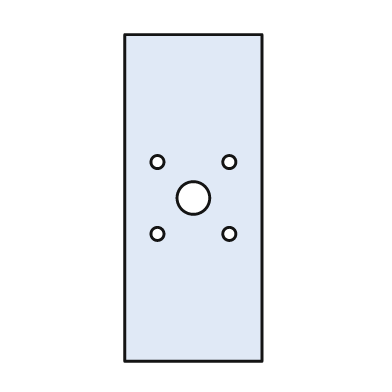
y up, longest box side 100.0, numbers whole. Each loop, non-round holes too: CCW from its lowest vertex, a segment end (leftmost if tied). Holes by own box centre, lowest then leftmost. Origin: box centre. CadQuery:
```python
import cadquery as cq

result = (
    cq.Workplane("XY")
    .moveTo(-21.0, -50.0)
    .lineTo(21.0, -50.0)
    .lineTo(21.0, 50.0)
    .lineTo(-21.0, 50.0)
    .close()
    .moveTo(-11.0, -11.0)
    .circle(2.0)
    .moveTo(11.0, -11.0)
    .circle(2.0)
    .moveTo(0.0, 0.0)
    .circle(5.0)
    .moveTo(-11.0, 11.0)
    .circle(2.0)
    .moveTo(11.0, 11.0)
    .circle(2.0)
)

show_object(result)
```